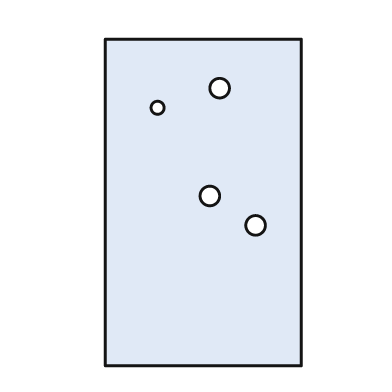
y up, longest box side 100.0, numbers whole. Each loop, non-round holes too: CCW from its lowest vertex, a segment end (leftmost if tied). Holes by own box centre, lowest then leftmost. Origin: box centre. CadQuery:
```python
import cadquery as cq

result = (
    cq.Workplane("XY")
    .moveTo(-30.0, -50.0)
    .lineTo(30.0, -50.0)
    .lineTo(30.0, 50.0)
    .lineTo(-30.0, 50.0)
    .close()
    .moveTo(16.0, -7.0)
    .circle(3.0)
    .moveTo(2.0, 2.0)
    .circle(3.0)
    .moveTo(-14.0, 29.0)
    .circle(2.0)
    .moveTo(5.0, 35.0)
    .circle(3.0)
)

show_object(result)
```